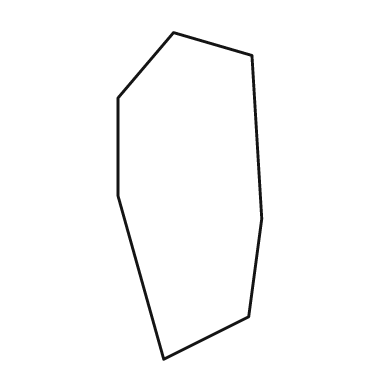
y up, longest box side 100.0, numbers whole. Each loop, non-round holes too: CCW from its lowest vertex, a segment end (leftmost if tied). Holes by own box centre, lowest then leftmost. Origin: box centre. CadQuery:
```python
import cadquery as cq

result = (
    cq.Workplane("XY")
    .moveTo(-8.0, -50.0)
    .lineTo(18.0, -37.0)
    .lineTo(22.0, -7.0)
    .lineTo(19.0, 43.0)
    .lineTo(-5.0, 50.0)
    .lineTo(-22.0, 30.0)
    .lineTo(-22.0, 0.0)
    .close()
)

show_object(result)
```